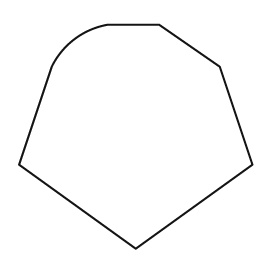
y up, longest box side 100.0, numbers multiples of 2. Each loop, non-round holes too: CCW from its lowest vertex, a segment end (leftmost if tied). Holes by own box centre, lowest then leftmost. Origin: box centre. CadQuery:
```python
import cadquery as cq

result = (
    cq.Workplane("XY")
    .moveTo(0.0, -48.0)
    .lineTo(50.0, -12.0)
    .lineTo(36.0, 30.0)
    .lineTo(10.0, 48.0)
    .lineTo(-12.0, 48.0)
    .threePointArc((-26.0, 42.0), (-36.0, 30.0))
    .lineTo(-50.0, -12.0)
    .close()
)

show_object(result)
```